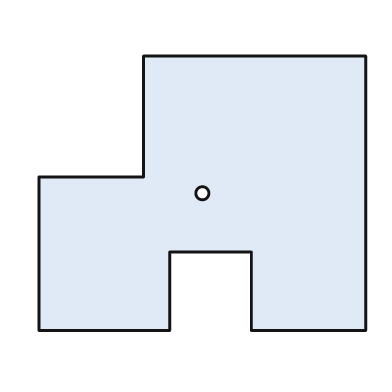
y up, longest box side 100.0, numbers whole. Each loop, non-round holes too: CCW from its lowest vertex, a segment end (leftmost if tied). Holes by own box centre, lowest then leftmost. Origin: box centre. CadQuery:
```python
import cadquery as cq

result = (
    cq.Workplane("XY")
    .moveTo(-50.0, -42.0)
    .lineTo(-10.0, -42.0)
    .lineTo(-10.0, -18.0)
    .lineTo(15.0, -18.0)
    .lineTo(15.0, -42.0)
    .lineTo(50.0, -42.0)
    .lineTo(50.0, 42.0)
    .lineTo(-18.0, 42.0)
    .lineTo(-18.0, 5.0)
    .lineTo(-50.0, 5.0)
    .close()
    .moveTo(0.0, 0.0)
    .circle(2.0)
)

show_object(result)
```